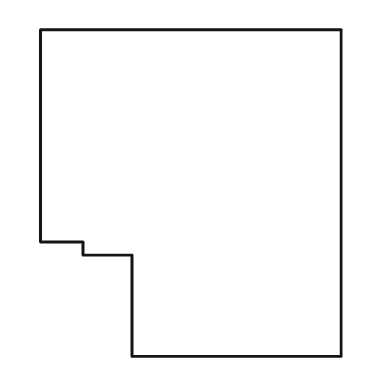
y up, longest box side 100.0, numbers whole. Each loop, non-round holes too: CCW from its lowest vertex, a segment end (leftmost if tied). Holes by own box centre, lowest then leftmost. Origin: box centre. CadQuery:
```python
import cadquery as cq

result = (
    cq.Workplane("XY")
    .moveTo(-18.0, -50.0)
    .lineTo(46.0, -50.0)
    .lineTo(46.0, 50.0)
    .lineTo(-46.0, 50.0)
    .lineTo(-46.0, -15.0)
    .lineTo(-33.0, -15.0)
    .lineTo(-33.0, -19.0)
    .lineTo(-18.0, -19.0)
    .close()
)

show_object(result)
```